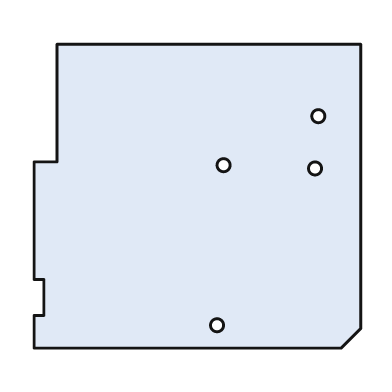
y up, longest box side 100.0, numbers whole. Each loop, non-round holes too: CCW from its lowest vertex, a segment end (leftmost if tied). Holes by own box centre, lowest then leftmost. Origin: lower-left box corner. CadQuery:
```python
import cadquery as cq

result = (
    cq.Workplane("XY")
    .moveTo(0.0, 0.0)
    .lineTo(94.0, 0.0)
    .lineTo(100.0, 6.0)
    .lineTo(100.0, 93.0)
    .lineTo(7.0, 93.0)
    .lineTo(7.0, 57.0)
    .lineTo(0.0, 57.0)
    .lineTo(0.0, 21.0)
    .lineTo(3.0, 21.0)
    .lineTo(3.0, 10.0)
    .lineTo(0.0, 10.0)
    .close()
    .moveTo(56.0, 7.0)
    .circle(2.0)
    .moveTo(86.0, 55.0)
    .circle(2.0)
    .moveTo(58.0, 56.0)
    .circle(2.0)
    .moveTo(87.0, 71.0)
    .circle(2.0)
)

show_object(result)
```